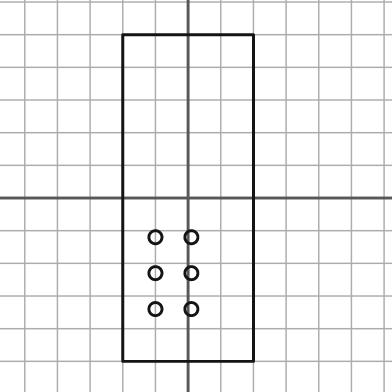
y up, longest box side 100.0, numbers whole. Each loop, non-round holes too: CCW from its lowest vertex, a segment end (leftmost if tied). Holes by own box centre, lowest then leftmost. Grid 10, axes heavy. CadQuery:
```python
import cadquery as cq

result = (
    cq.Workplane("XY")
    .moveTo(-20.0, -50.0)
    .lineTo(20.0, -50.0)
    .lineTo(20.0, 50.0)
    .lineTo(-20.0, 50.0)
    .close()
    .moveTo(-10.0, -34.0)
    .circle(2.0)
    .moveTo(1.0, -34.0)
    .circle(2.0)
    .moveTo(-10.0, -23.0)
    .circle(2.0)
    .moveTo(1.0, -23.0)
    .circle(2.0)
    .moveTo(-10.0, -12.0)
    .circle(2.0)
    .moveTo(1.0, -12.0)
    .circle(2.0)
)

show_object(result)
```